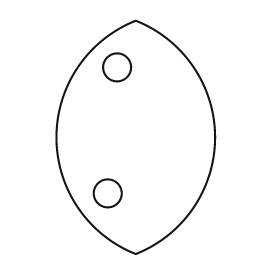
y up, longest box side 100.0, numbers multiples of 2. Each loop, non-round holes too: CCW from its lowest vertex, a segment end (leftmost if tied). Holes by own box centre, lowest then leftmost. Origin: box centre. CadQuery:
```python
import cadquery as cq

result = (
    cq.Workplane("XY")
    .moveTo(0.0, -50.0)
    .threePointArc((34.0, 0.0), (0.0, 50.0))
    .threePointArc((-34.0, 0.0), (0.0, -50.0))
    .close()
    .moveTo(-12.0, -24.0)
    .circle(6.0)
    .moveTo(-8.0, 30.0)
    .circle(6.0)
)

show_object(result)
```